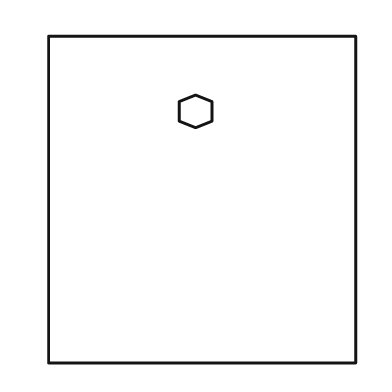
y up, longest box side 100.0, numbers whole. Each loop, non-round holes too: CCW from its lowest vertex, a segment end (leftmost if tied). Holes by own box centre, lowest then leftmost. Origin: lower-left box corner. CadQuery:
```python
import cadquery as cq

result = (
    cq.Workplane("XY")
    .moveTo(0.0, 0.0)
    .lineTo(94.0, 0.0)
    .lineTo(94.0, 100.0)
    .lineTo(0.0, 100.0)
    .close()
    .moveTo(45.0, 72.0)
    .lineTo(50.0, 74.0)
    .lineTo(50.0, 80.0)
    .lineTo(45.0, 82.0)
    .lineTo(40.0, 80.0)
    .lineTo(40.0, 74.0)
    .close()
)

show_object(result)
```